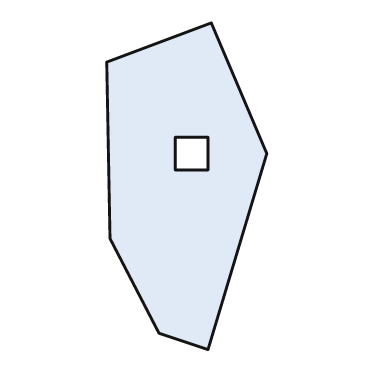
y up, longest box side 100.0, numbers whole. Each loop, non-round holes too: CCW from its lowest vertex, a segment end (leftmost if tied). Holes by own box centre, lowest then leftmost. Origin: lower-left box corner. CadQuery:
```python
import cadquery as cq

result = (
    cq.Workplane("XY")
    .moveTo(31.0, 0.0)
    .lineTo(49.0, 60.0)
    .lineTo(32.0, 100.0)
    .lineTo(0.0, 88.0)
    .lineTo(1.0, 34.0)
    .lineTo(16.0, 5.0)
    .close()
    .moveTo(21.0, 55.0)
    .lineTo(31.0, 55.0)
    .lineTo(31.0, 65.0)
    .lineTo(21.0, 65.0)
    .close()
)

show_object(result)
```